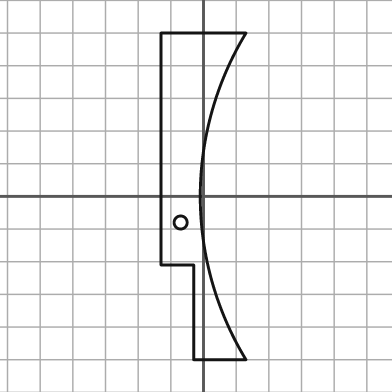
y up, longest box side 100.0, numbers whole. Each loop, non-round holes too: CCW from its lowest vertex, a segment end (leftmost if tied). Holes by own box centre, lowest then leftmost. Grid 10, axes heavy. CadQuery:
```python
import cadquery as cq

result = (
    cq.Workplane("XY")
    .moveTo(-3.0, -50.0)
    .lineTo(13.0, -50.0)
    .threePointArc((-1.0, 0.0), (13.0, 50.0))
    .lineTo(-13.0, 50.0)
    .lineTo(-13.0, -21.0)
    .lineTo(-3.0, -21.0)
    .close()
    .moveTo(-7.0, -8.0)
    .circle(2.0)
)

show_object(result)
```